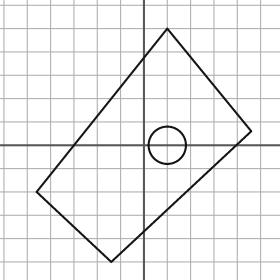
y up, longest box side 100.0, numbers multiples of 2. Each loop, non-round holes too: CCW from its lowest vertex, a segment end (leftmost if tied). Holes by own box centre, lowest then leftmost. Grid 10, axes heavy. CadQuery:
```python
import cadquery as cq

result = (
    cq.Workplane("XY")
    .moveTo(-14.0, -50.0)
    .lineTo(46.0, 6.0)
    .lineTo(10.0, 50.0)
    .lineTo(-46.0, -20.0)
    .close()
    .moveTo(10.0, 0.0)
    .circle(8.0)
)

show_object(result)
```